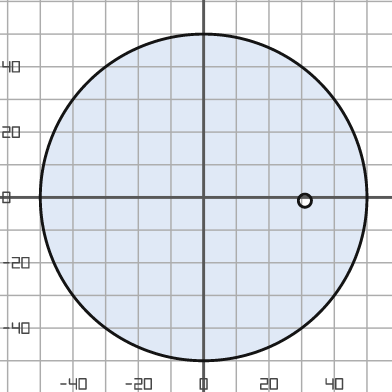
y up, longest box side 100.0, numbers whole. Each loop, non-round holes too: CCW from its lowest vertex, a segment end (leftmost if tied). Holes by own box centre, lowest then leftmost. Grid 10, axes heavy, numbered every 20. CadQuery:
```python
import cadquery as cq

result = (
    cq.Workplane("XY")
    .moveTo(0.0, 0.0)
    .circle(50.0)
    .moveTo(31.0, -1.0)
    .circle(2.0)
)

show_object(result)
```